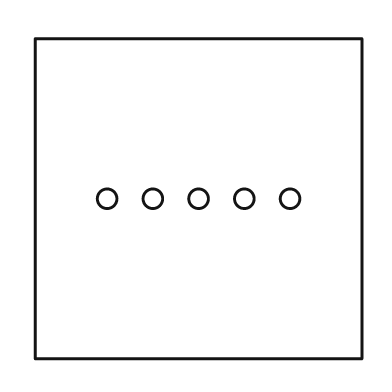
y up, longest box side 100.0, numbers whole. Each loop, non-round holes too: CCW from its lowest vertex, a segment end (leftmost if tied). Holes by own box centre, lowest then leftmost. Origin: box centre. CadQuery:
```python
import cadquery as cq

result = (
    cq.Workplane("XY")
    .moveTo(-50.0, -49.0)
    .lineTo(50.0, -49.0)
    .lineTo(50.0, 49.0)
    .lineTo(-50.0, 49.0)
    .close()
    .moveTo(-28.0, 0.0)
    .circle(3.0)
    .moveTo(-14.0, 0.0)
    .circle(3.0)
    .moveTo(0.0, 0.0)
    .circle(3.0)
    .moveTo(14.0, 0.0)
    .circle(3.0)
    .moveTo(28.0, 0.0)
    .circle(3.0)
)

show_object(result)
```